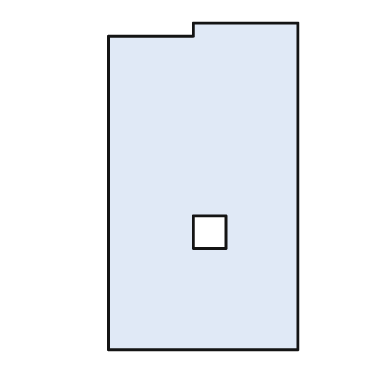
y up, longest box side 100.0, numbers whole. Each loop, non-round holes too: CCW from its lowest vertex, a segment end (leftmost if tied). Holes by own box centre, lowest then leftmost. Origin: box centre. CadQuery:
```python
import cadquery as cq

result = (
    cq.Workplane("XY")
    .moveTo(-29.0, -50.0)
    .lineTo(29.0, -50.0)
    .lineTo(29.0, 50.0)
    .lineTo(-3.0, 50.0)
    .lineTo(-3.0, 46.0)
    .lineTo(-29.0, 46.0)
    .close()
    .moveTo(-3.0, -19.0)
    .lineTo(7.0, -19.0)
    .lineTo(7.0, -9.0)
    .lineTo(-3.0, -9.0)
    .close()
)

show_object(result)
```